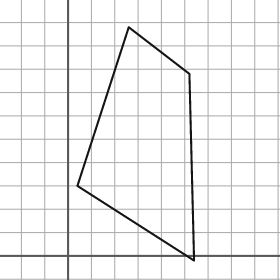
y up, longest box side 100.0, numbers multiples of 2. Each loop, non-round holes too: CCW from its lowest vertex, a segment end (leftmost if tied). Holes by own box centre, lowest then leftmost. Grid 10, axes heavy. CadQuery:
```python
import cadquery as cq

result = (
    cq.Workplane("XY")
    .moveTo(54.0, -2.0)
    .lineTo(52.0, 78.0)
    .lineTo(26.0, 98.0)
    .lineTo(4.0, 30.0)
    .close()
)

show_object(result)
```